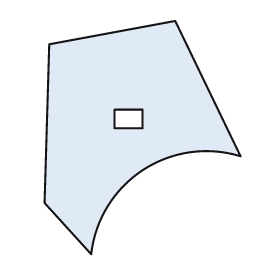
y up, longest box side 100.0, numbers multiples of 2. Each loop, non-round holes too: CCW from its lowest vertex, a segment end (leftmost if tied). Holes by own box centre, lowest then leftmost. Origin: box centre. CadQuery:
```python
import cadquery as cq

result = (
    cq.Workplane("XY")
    .moveTo(-22.0, -50.0)
    .threePointArc((0.0, -14.0), (42.0, -8.0))
    .lineTo(14.0, 50.0)
    .lineTo(-40.0, 40.0)
    .lineTo(-42.0, -28.0)
    .close()
    .moveTo(-12.0, 4.0)
    .lineTo(0.0, 4.0)
    .lineTo(0.0, 12.0)
    .lineTo(-12.0, 12.0)
    .close()
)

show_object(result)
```